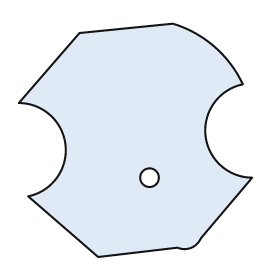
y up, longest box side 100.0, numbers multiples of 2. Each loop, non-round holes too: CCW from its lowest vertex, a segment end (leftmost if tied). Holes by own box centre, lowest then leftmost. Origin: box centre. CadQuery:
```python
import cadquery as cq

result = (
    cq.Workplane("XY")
    .moveTo(-16.0, -50.0)
    .lineTo(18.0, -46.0)
    .threePointArc((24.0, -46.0), (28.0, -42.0))
    .lineTo(50.0, -16.0)
    .threePointArc((30.0, 2.0), (46.0, 24.0))
    .threePointArc((34.0, 40.0), (16.0, 50.0))
    .lineTo(-24.0, 46.0)
    .lineTo(-50.0, 16.0)
    .threePointArc((-30.0, -2.0), (-46.0, -24.0))
    .close()
    .moveTo(6.0, -16.0)
    .circle(4.0)
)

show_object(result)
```